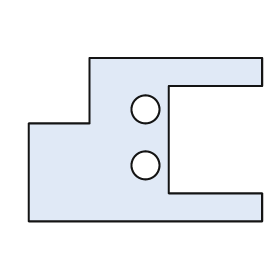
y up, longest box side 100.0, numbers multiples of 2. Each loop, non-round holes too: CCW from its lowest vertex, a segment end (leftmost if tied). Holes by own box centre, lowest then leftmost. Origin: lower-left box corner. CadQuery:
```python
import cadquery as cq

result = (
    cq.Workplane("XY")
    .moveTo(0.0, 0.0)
    .lineTo(100.0, 0.0)
    .lineTo(100.0, 12.0)
    .lineTo(60.0, 12.0)
    .lineTo(60.0, 58.0)
    .lineTo(100.0, 58.0)
    .lineTo(100.0, 70.0)
    .lineTo(26.0, 70.0)
    .lineTo(26.0, 42.0)
    .lineTo(0.0, 42.0)
    .close()
    .moveTo(50.0, 24.0)
    .circle(6.0)
    .moveTo(50.0, 48.0)
    .circle(6.0)
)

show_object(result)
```